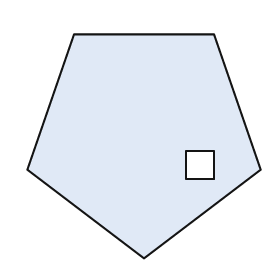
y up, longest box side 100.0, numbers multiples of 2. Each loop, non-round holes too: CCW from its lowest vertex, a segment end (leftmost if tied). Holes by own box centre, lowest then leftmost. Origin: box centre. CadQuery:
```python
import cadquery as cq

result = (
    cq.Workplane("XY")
    .moveTo(0.0, -48.0)
    .lineTo(50.0, -10.0)
    .lineTo(30.0, 48.0)
    .lineTo(-30.0, 48.0)
    .lineTo(-50.0, -10.0)
    .close()
    .moveTo(18.0, -14.0)
    .lineTo(30.0, -14.0)
    .lineTo(30.0, -2.0)
    .lineTo(18.0, -2.0)
    .close()
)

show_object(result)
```